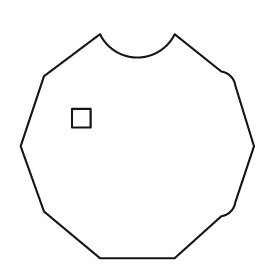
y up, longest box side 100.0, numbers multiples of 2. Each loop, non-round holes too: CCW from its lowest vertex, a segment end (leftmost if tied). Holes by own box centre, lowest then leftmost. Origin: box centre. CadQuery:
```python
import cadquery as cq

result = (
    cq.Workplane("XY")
    .moveTo(-16.0, -48.0)
    .lineTo(16.0, -48.0)
    .lineTo(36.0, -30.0)
    .threePointArc((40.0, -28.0), (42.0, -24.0))
    .lineTo(50.0, 0.0)
    .lineTo(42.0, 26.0)
    .threePointArc((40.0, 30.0), (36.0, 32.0))
    .lineTo(16.0, 48.0)
    .threePointArc((0.0, 38.0), (-16.0, 48.0))
    .lineTo(-40.0, 30.0)
    .lineTo(-50.0, 0.0)
    .lineTo(-40.0, -28.0)
    .close()
    .moveTo(-28.0, 8.0)
    .lineTo(-20.0, 8.0)
    .lineTo(-20.0, 16.0)
    .lineTo(-28.0, 16.0)
    .close()
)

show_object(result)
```